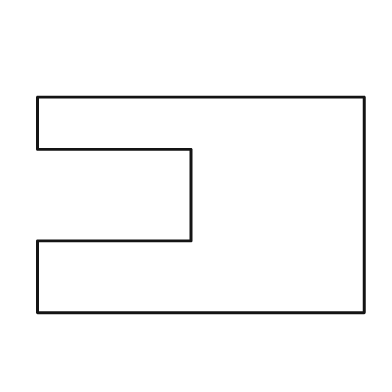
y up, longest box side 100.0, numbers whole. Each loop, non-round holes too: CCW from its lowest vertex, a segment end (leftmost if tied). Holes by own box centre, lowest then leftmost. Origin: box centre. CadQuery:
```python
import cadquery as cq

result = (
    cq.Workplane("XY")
    .moveTo(-50.0, -33.0)
    .lineTo(50.0, -33.0)
    .lineTo(50.0, 33.0)
    .lineTo(-50.0, 33.0)
    .lineTo(-50.0, 17.0)
    .lineTo(-3.0, 17.0)
    .lineTo(-3.0, -11.0)
    .lineTo(-50.0, -11.0)
    .close()
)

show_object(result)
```